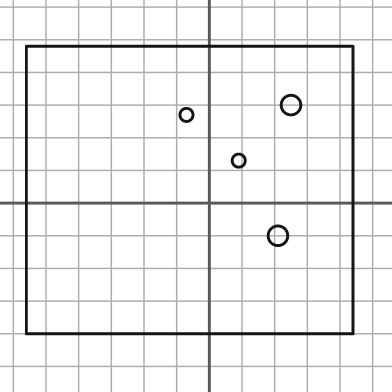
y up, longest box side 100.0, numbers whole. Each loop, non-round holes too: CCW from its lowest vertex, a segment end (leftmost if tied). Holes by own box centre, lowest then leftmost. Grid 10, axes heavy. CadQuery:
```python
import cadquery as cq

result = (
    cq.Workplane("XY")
    .moveTo(-56.0, -40.0)
    .lineTo(44.0, -40.0)
    .lineTo(44.0, 48.0)
    .lineTo(-56.0, 48.0)
    .close()
    .moveTo(21.0, -10.0)
    .circle(3.0)
    .moveTo(9.0, 13.0)
    .circle(2.0)
    .moveTo(-7.0, 27.0)
    .circle(2.0)
    .moveTo(25.0, 30.0)
    .circle(3.0)
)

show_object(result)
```